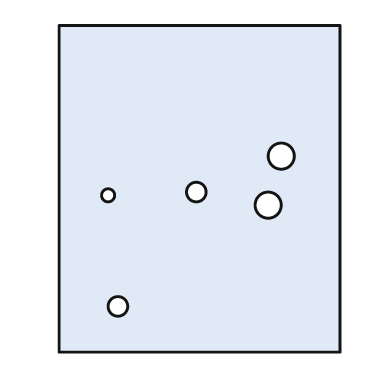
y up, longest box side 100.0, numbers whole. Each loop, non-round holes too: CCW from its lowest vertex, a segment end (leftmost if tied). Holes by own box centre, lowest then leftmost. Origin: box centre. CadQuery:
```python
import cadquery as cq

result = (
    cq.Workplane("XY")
    .moveTo(-43.0, -50.0)
    .lineTo(43.0, -50.0)
    .lineTo(43.0, 50.0)
    .lineTo(-43.0, 50.0)
    .close()
    .moveTo(-25.0, -36.0)
    .circle(3.0)
    .moveTo(21.0, -5.0)
    .circle(4.0)
    .moveTo(-28.0, -2.0)
    .circle(2.0)
    .moveTo(-1.0, -1.0)
    .circle(3.0)
    .moveTo(25.0, 10.0)
    .circle(4.0)
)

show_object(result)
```